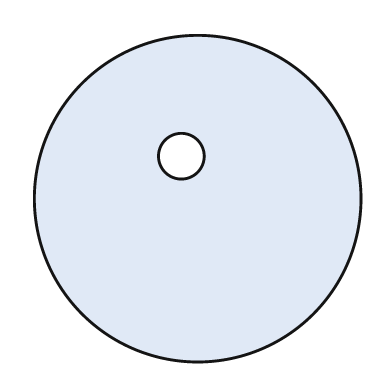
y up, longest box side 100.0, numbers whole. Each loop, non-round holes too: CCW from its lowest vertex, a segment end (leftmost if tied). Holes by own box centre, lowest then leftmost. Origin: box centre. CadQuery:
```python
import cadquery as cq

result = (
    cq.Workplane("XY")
    .moveTo(0.0, 0.0)
    .circle(50.0)
    .moveTo(-5.0, 13.0)
    .circle(7.0)
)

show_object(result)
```